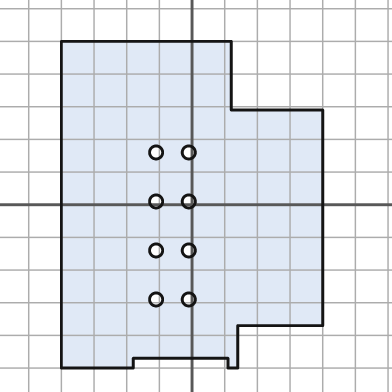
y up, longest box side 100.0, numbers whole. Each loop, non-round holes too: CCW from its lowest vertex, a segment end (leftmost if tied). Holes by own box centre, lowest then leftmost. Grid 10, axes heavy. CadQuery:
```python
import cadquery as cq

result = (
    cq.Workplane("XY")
    .moveTo(-40.0, -50.0)
    .lineTo(-18.0, -50.0)
    .lineTo(-18.0, -47.0)
    .lineTo(11.0, -47.0)
    .lineTo(11.0, -50.0)
    .lineTo(14.0, -50.0)
    .lineTo(14.0, -37.0)
    .lineTo(40.0, -37.0)
    .lineTo(40.0, 29.0)
    .lineTo(12.0, 29.0)
    .lineTo(12.0, 50.0)
    .lineTo(-40.0, 50.0)
    .close()
    .moveTo(-11.0, -29.0)
    .circle(2.0)
    .moveTo(-1.0, -29.0)
    .circle(2.0)
    .moveTo(-11.0, -14.0)
    .circle(2.0)
    .moveTo(-1.0, -14.0)
    .circle(2.0)
    .moveTo(-11.0, 1.0)
    .circle(2.0)
    .moveTo(-1.0, 1.0)
    .circle(2.0)
    .moveTo(-11.0, 16.0)
    .circle(2.0)
    .moveTo(-1.0, 16.0)
    .circle(2.0)
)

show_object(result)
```